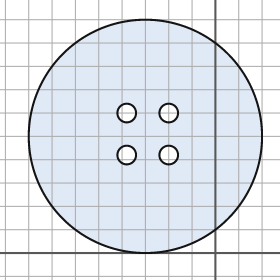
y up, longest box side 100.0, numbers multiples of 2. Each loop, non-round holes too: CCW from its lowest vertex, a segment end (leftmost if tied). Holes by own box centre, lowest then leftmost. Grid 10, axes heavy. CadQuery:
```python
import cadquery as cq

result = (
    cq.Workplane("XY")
    .moveTo(-30.0, 50.0)
    .circle(50.0)
    .moveTo(-38.0, 42.0)
    .circle(4.0)
    .moveTo(-20.0, 42.0)
    .circle(4.0)
    .moveTo(-38.0, 60.0)
    .circle(4.0)
    .moveTo(-20.0, 60.0)
    .circle(4.0)
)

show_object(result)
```